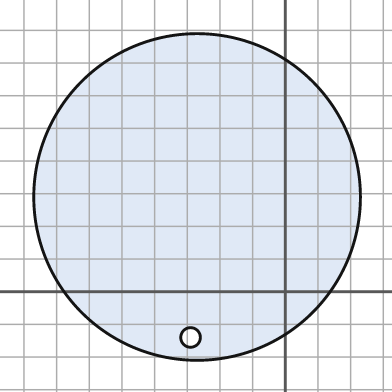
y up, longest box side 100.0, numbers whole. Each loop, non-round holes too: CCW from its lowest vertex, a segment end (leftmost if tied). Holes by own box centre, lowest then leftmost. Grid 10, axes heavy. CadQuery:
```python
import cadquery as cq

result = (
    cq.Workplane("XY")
    .moveTo(-27.0, 29.0)
    .circle(50.0)
    .moveTo(-29.0, -14.0)
    .circle(3.0)
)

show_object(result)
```